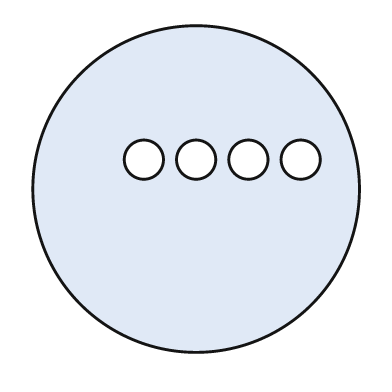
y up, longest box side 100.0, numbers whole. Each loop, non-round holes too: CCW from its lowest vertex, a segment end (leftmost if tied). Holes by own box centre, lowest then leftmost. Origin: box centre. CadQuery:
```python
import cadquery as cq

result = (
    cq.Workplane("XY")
    .moveTo(0.0, 0.0)
    .circle(50.0)
    .moveTo(-16.0, 9.0)
    .circle(6.0)
    .moveTo(0.0, 9.0)
    .circle(6.0)
    .moveTo(16.0, 9.0)
    .circle(6.0)
    .moveTo(32.0, 9.0)
    .circle(6.0)
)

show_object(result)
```